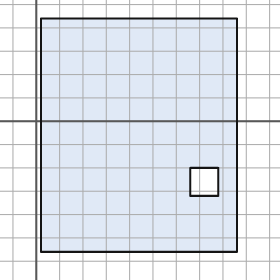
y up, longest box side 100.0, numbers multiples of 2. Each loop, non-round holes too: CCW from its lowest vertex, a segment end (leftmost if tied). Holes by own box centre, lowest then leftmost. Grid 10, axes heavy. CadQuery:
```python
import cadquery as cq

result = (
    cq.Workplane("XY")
    .moveTo(2.0, -56.0)
    .lineTo(86.0, -56.0)
    .lineTo(86.0, 44.0)
    .lineTo(2.0, 44.0)
    .close()
    .moveTo(66.0, -32.0)
    .lineTo(78.0, -32.0)
    .lineTo(78.0, -20.0)
    .lineTo(66.0, -20.0)
    .close()
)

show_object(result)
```